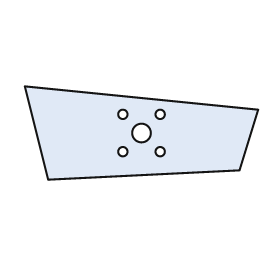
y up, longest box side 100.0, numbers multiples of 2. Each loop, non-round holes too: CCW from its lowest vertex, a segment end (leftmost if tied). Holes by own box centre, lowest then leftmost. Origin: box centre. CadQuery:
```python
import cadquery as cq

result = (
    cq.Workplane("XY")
    .moveTo(-40.0, -20.0)
    .lineTo(42.0, -16.0)
    .lineTo(50.0, 10.0)
    .lineTo(-50.0, 20.0)
    .close()
    .moveTo(-8.0, -8.0)
    .circle(2.0)
    .moveTo(8.0, -8.0)
    .circle(2.0)
    .moveTo(0.0, 0.0)
    .circle(4.0)
    .moveTo(-8.0, 8.0)
    .circle(2.0)
    .moveTo(8.0, 8.0)
    .circle(2.0)
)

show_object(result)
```